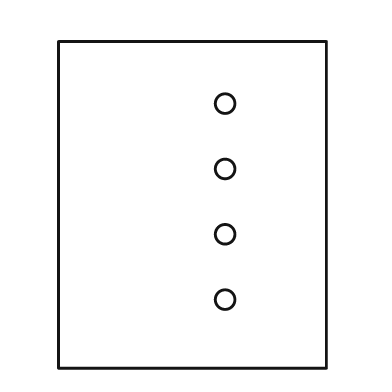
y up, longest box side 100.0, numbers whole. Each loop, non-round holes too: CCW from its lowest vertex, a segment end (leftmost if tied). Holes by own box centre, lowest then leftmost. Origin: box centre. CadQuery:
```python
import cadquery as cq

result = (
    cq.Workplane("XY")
    .moveTo(-41.0, -50.0)
    .lineTo(41.0, -50.0)
    .lineTo(41.0, 50.0)
    .lineTo(-41.0, 50.0)
    .close()
    .moveTo(10.0, -29.0)
    .circle(3.0)
    .moveTo(10.0, -9.0)
    .circle(3.0)
    .moveTo(10.0, 11.0)
    .circle(3.0)
    .moveTo(10.0, 31.0)
    .circle(3.0)
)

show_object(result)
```